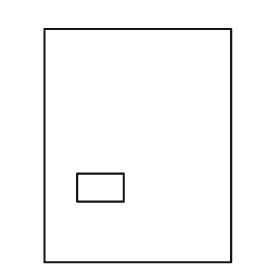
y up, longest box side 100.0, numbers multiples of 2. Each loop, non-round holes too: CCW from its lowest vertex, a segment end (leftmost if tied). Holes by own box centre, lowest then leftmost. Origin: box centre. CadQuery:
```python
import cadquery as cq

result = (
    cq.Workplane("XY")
    .moveTo(-40.0, -50.0)
    .lineTo(40.0, -50.0)
    .lineTo(40.0, 50.0)
    .lineTo(-40.0, 50.0)
    .close()
    .moveTo(-26.0, -24.0)
    .lineTo(-6.0, -24.0)
    .lineTo(-6.0, -12.0)
    .lineTo(-26.0, -12.0)
    .close()
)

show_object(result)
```